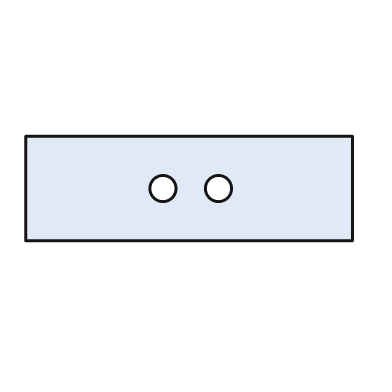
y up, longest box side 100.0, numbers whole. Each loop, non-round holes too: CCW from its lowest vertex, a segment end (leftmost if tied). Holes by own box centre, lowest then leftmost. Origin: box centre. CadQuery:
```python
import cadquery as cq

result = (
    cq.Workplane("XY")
    .moveTo(-50.0, -16.0)
    .lineTo(50.0, -16.0)
    .lineTo(50.0, 16.0)
    .lineTo(-50.0, 16.0)
    .close()
    .moveTo(-8.0, 0.0)
    .circle(4.0)
    .moveTo(9.0, 0.0)
    .circle(4.0)
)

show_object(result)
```